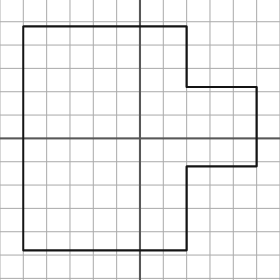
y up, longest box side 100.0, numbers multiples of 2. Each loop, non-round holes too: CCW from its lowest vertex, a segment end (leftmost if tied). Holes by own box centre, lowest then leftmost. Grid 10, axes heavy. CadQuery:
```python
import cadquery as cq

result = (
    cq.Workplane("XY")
    .moveTo(-50.0, -48.0)
    .lineTo(20.0, -48.0)
    .lineTo(20.0, -12.0)
    .lineTo(50.0, -12.0)
    .lineTo(50.0, 22.0)
    .lineTo(20.0, 22.0)
    .lineTo(20.0, 48.0)
    .lineTo(-50.0, 48.0)
    .close()
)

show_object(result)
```